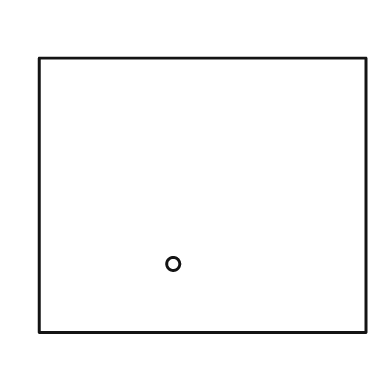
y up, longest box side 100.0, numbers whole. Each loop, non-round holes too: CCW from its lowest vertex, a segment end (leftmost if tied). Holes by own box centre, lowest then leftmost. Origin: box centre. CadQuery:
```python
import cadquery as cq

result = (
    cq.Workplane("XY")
    .moveTo(-50.0, -42.0)
    .lineTo(50.0, -42.0)
    .lineTo(50.0, 42.0)
    .lineTo(-50.0, 42.0)
    .close()
    .moveTo(-9.0, -21.0)
    .circle(2.0)
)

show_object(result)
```